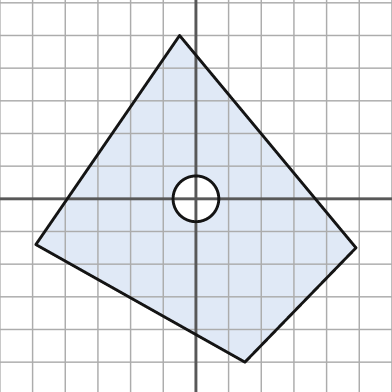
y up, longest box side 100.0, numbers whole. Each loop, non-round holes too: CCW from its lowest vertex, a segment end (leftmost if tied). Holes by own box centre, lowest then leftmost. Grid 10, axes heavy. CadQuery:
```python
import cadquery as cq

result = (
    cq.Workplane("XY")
    .moveTo(15.0, -50.0)
    .lineTo(49.0, -15.0)
    .lineTo(-5.0, 50.0)
    .lineTo(-49.0, -14.0)
    .close()
    .moveTo(0.0, 0.0)
    .circle(7.0)
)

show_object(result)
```